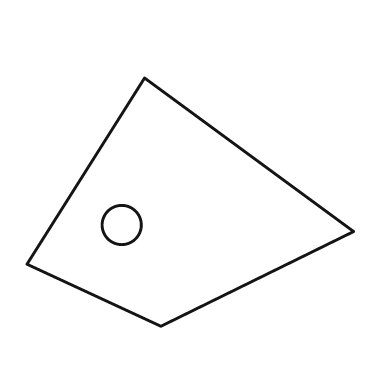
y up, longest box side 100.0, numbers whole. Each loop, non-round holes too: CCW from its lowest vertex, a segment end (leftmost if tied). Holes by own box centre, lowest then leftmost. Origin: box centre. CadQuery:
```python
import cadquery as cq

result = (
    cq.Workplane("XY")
    .moveTo(-9.0, -38.0)
    .lineTo(50.0, -9.0)
    .lineTo(-14.0, 38.0)
    .lineTo(-50.0, -19.0)
    .close()
    .moveTo(-21.0, -7.0)
    .circle(6.0)
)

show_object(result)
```